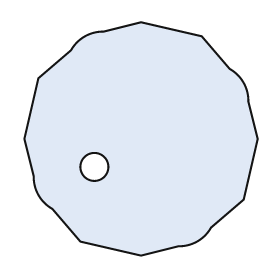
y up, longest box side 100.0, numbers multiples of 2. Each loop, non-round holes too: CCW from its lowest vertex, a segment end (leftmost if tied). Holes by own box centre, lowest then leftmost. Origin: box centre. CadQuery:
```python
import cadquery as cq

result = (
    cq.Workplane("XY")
    .moveTo(0.0, -50.0)
    .lineTo(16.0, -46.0)
    .threePointArc((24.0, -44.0), (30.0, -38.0))
    .lineTo(44.0, -26.0)
    .lineTo(50.0, 0.0)
    .lineTo(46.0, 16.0)
    .threePointArc((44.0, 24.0), (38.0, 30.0))
    .lineTo(26.0, 44.0)
    .lineTo(0.0, 50.0)
    .lineTo(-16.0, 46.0)
    .threePointArc((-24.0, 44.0), (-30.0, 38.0))
    .lineTo(-44.0, 26.0)
    .lineTo(-50.0, 0.0)
    .lineTo(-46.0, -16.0)
    .threePointArc((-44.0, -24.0), (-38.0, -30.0))
    .lineTo(-26.0, -44.0)
    .close()
    .moveTo(-20.0, -12.0)
    .circle(6.0)
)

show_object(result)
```